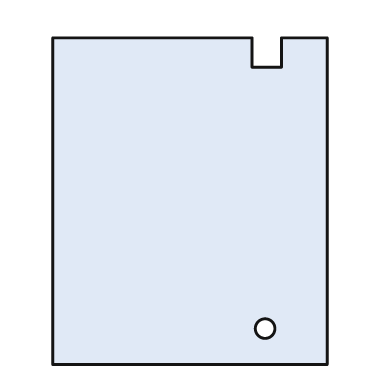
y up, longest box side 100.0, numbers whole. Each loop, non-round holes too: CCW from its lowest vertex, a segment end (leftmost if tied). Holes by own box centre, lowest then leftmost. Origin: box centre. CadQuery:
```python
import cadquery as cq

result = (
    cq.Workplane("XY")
    .moveTo(-42.0, -50.0)
    .lineTo(42.0, -50.0)
    .lineTo(42.0, 50.0)
    .lineTo(28.0, 50.0)
    .lineTo(28.0, 41.0)
    .lineTo(19.0, 41.0)
    .lineTo(19.0, 50.0)
    .lineTo(-42.0, 50.0)
    .close()
    .moveTo(23.0, -39.0)
    .circle(3.0)
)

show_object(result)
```